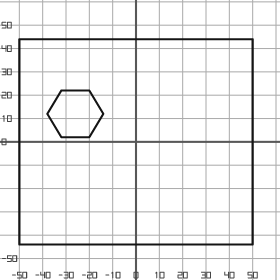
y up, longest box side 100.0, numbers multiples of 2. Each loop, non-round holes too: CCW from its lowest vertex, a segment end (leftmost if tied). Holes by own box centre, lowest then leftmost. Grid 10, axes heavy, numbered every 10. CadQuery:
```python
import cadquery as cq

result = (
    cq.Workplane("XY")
    .moveTo(-50.0, -44.0)
    .lineTo(50.0, -44.0)
    .lineTo(50.0, 44.0)
    .lineTo(-50.0, 44.0)
    .close()
    .moveTo(-32.0, 2.0)
    .lineTo(-20.0, 2.0)
    .lineTo(-14.0, 12.0)
    .lineTo(-20.0, 22.0)
    .lineTo(-32.0, 22.0)
    .lineTo(-38.0, 12.0)
    .close()
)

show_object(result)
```